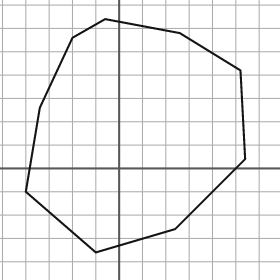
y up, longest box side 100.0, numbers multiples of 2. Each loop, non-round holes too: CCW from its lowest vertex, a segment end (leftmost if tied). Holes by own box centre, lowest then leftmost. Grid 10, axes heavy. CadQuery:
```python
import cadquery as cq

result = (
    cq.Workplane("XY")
    .moveTo(-10.0, -36.0)
    .lineTo(24.0, -26.0)
    .lineTo(54.0, 4.0)
    .lineTo(52.0, 42.0)
    .lineTo(26.0, 58.0)
    .lineTo(-6.0, 64.0)
    .lineTo(-20.0, 56.0)
    .lineTo(-34.0, 26.0)
    .lineTo(-40.0, -10.0)
    .close()
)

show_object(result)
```